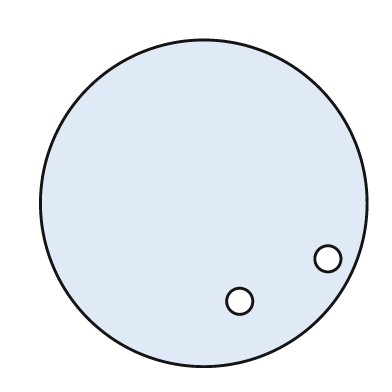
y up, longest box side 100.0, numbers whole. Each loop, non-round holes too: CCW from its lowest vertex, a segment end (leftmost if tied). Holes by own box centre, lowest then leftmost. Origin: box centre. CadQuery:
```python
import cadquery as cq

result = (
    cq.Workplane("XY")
    .moveTo(0.0, 0.0)
    .circle(50.0)
    .moveTo(11.0, -30.0)
    .circle(4.0)
    .moveTo(38.0, -17.0)
    .circle(4.0)
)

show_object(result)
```